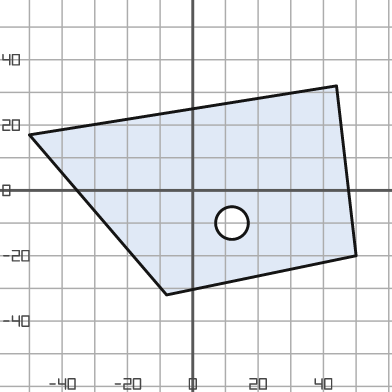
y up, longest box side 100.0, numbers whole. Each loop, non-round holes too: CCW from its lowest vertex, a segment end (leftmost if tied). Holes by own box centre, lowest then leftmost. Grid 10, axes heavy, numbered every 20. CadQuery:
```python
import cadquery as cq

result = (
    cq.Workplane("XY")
    .moveTo(-8.0, -32.0)
    .lineTo(50.0, -20.0)
    .lineTo(44.0, 32.0)
    .lineTo(-50.0, 17.0)
    .close()
    .moveTo(12.0, -10.0)
    .circle(5.0)
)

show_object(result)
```